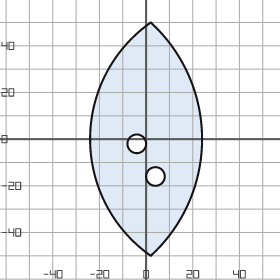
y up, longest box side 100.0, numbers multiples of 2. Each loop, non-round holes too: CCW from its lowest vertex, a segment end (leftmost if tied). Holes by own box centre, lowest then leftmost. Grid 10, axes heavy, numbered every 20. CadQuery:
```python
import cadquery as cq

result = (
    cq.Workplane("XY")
    .moveTo(2.0, -50.0)
    .threePointArc((24.0, 0.0), (2.0, 50.0))
    .threePointArc((-24.0, 0.0), (2.0, -50.0))
    .close()
    .moveTo(4.0, -16.0)
    .circle(4.0)
    .moveTo(-4.0, -2.0)
    .circle(4.0)
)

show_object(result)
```